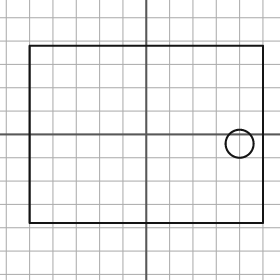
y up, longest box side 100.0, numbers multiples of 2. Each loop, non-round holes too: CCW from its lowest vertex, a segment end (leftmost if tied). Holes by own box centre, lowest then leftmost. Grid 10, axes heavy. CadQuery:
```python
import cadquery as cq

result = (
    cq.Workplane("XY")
    .moveTo(-50.0, -38.0)
    .lineTo(50.0, -38.0)
    .lineTo(50.0, 38.0)
    .lineTo(-50.0, 38.0)
    .close()
    .moveTo(40.0, -4.0)
    .circle(6.0)
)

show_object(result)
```